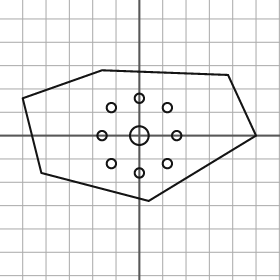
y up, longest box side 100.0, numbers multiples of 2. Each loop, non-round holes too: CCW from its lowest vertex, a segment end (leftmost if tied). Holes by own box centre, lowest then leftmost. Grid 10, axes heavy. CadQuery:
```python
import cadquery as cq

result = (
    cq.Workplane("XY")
    .moveTo(4.0, -28.0)
    .lineTo(50.0, 0.0)
    .lineTo(38.0, 26.0)
    .lineTo(-16.0, 28.0)
    .lineTo(-50.0, 16.0)
    .lineTo(-42.0, -16.0)
    .close()
    .moveTo(0.0, -16.0)
    .circle(2.0)
    .moveTo(-12.0, -12.0)
    .circle(2.0)
    .moveTo(12.0, -12.0)
    .circle(2.0)
    .moveTo(-16.0, 0.0)
    .circle(2.0)
    .moveTo(0.0, 0.0)
    .circle(4.0)
    .moveTo(16.0, 0.0)
    .circle(2.0)
    .moveTo(-12.0, 12.0)
    .circle(2.0)
    .moveTo(12.0, 12.0)
    .circle(2.0)
    .moveTo(0.0, 16.0)
    .circle(2.0)
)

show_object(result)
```